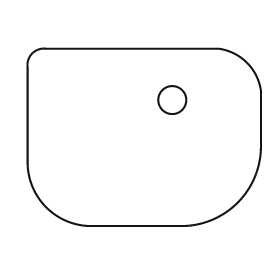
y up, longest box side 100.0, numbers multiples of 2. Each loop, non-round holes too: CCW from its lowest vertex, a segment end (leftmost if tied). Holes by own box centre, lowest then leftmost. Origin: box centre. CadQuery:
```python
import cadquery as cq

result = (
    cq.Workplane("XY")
    .moveTo(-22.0, -38.0)
    .lineTo(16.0, -38.0)
    .threePointArc((40.0, -28.0), (50.0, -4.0))
    .lineTo(50.0, 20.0)
    .threePointArc((44.0, 32.0), (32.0, 38.0))
    .lineTo(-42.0, 38.0)
    .threePointArc((-48.0, 36.0), (-50.0, 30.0))
    .lineTo(-50.0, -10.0)
    .threePointArc((-42.0, -30.0), (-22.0, -38.0))
    .close()
    .moveTo(12.0, 16.0)
    .circle(6.0)
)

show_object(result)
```